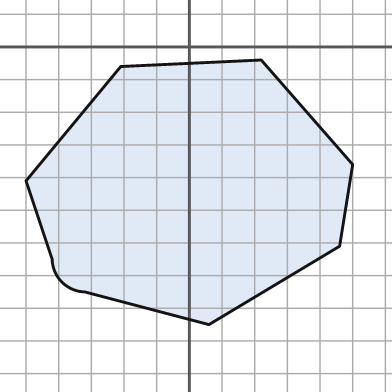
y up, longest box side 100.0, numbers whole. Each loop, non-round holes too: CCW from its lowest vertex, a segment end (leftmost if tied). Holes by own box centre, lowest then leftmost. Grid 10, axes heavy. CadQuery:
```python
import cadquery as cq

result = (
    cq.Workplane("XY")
    .moveTo(6.0, -85.0)
    .lineTo(46.0, -61.0)
    .lineTo(50.0, -36.0)
    .lineTo(22.0, -4.0)
    .lineTo(-21.0, -6.0)
    .lineTo(-50.0, -41.0)
    .lineTo(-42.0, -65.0)
    .threePointArc((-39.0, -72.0), (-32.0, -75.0))
    .close()
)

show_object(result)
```